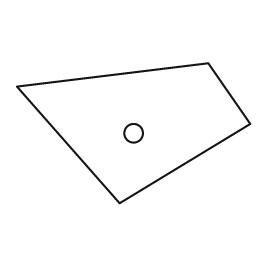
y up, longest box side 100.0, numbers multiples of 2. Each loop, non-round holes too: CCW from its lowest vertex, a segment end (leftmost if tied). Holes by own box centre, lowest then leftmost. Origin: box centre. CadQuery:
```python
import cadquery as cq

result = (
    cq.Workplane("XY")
    .moveTo(-6.0, -30.0)
    .lineTo(50.0, 4.0)
    .lineTo(32.0, 30.0)
    .lineTo(-50.0, 20.0)
    .close()
    .moveTo(0.0, 0.0)
    .circle(4.0)
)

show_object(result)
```